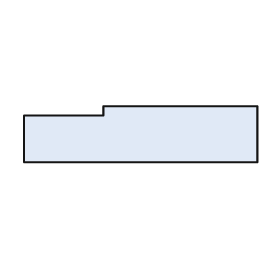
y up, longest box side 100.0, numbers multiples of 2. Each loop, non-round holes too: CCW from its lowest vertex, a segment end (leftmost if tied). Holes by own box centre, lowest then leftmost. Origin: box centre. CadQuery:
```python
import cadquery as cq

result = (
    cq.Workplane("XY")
    .moveTo(-50.0, -12.0)
    .lineTo(50.0, -12.0)
    .lineTo(50.0, 12.0)
    .lineTo(-16.0, 12.0)
    .lineTo(-16.0, 8.0)
    .lineTo(-50.0, 8.0)
    .close()
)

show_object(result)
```